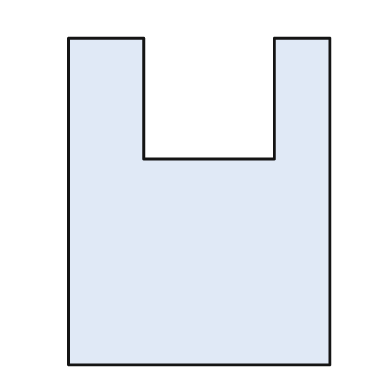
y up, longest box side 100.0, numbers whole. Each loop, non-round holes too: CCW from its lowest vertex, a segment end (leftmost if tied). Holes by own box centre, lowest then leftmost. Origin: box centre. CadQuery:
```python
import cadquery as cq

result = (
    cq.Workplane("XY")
    .moveTo(-40.0, -50.0)
    .lineTo(40.0, -50.0)
    .lineTo(40.0, 50.0)
    .lineTo(23.0, 50.0)
    .lineTo(23.0, 13.0)
    .lineTo(-17.0, 13.0)
    .lineTo(-17.0, 50.0)
    .lineTo(-40.0, 50.0)
    .close()
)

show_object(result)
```